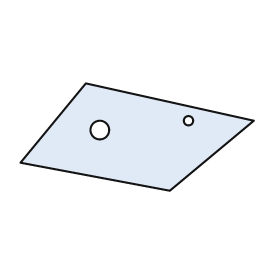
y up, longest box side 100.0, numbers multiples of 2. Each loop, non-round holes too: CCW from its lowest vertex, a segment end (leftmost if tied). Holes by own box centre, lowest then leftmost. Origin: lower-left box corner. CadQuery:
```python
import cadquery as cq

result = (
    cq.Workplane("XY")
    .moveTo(64.0, 0.0)
    .lineTo(100.0, 30.0)
    .lineTo(28.0, 46.0)
    .lineTo(0.0, 12.0)
    .close()
    .moveTo(34.0, 26.0)
    .circle(4.0)
    .moveTo(72.0, 30.0)
    .circle(2.0)
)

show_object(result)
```